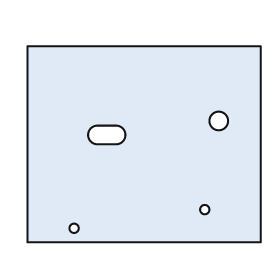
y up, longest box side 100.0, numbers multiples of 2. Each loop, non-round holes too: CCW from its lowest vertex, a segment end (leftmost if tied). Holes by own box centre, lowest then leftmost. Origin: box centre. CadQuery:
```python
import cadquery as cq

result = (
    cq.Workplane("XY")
    .moveTo(-50.0, -42.0)
    .lineTo(50.0, -42.0)
    .lineTo(50.0, 42.0)
    .lineTo(-50.0, 42.0)
    .close()
    .moveTo(-30.0, -36.0)
    .circle(2.0)
    .moveTo(26.0, -28.0)
    .circle(2.0)
    .moveTo(-20.0, 0.0)
    .lineTo(-12.0, 0.0)
    .threePointArc((-8.0, 4.0), (-12.0, 8.0))
    .lineTo(-20.0, 8.0)
    .threePointArc((-24.0, 4.0), (-20.0, 0.0))
    .close()
    .moveTo(32.0, 10.0)
    .circle(4.0)
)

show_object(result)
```